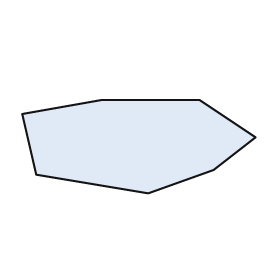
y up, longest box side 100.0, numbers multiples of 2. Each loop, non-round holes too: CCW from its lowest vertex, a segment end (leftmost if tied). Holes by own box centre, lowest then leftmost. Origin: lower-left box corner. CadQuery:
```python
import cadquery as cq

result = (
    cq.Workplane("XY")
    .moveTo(54.0, 0.0)
    .lineTo(82.0, 10.0)
    .lineTo(100.0, 24.0)
    .lineTo(76.0, 40.0)
    .lineTo(34.0, 40.0)
    .lineTo(0.0, 34.0)
    .lineTo(6.0, 8.0)
    .close()
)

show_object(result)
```